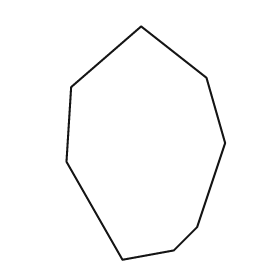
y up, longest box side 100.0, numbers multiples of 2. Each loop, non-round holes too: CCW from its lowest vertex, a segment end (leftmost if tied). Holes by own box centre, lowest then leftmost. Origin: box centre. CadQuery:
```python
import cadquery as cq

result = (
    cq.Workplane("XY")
    .moveTo(-10.0, -50.0)
    .lineTo(12.0, -46.0)
    .lineTo(22.0, -36.0)
    .lineTo(34.0, 0.0)
    .lineTo(26.0, 28.0)
    .lineTo(-2.0, 50.0)
    .lineTo(-32.0, 24.0)
    .lineTo(-34.0, -8.0)
    .close()
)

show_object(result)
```